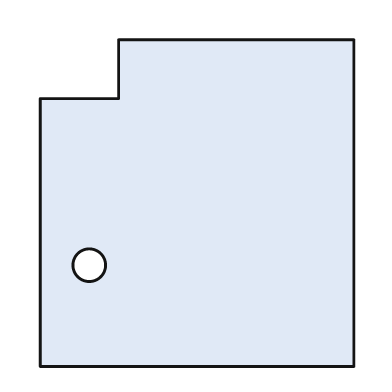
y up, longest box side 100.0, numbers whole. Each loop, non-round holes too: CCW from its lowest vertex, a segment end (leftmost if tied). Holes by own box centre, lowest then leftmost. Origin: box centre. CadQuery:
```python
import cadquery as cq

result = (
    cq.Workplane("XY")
    .moveTo(-48.0, -50.0)
    .lineTo(48.0, -50.0)
    .lineTo(48.0, 50.0)
    .lineTo(-24.0, 50.0)
    .lineTo(-24.0, 32.0)
    .lineTo(-48.0, 32.0)
    .close()
    .moveTo(-33.0, -19.0)
    .circle(5.0)
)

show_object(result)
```